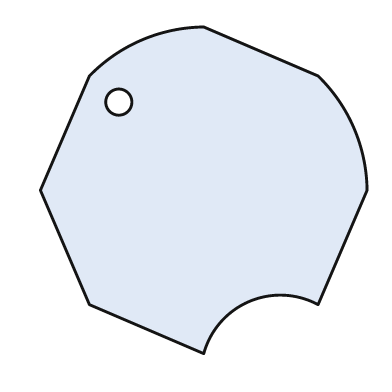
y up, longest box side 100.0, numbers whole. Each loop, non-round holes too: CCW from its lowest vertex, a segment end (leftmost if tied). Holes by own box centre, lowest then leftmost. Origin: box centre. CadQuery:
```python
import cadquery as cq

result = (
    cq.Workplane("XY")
    .moveTo(0.0, -50.0)
    .threePointArc((14.0, -34.0), (35.0, -35.0))
    .lineTo(50.0, 0.0)
    .threePointArc((46.0, 19.0), (35.0, 35.0))
    .lineTo(0.0, 50.0)
    .threePointArc((-19.0, 46.0), (-35.0, 35.0))
    .lineTo(-50.0, 0.0)
    .lineTo(-35.0, -35.0)
    .close()
    .moveTo(-26.0, 27.0)
    .circle(4.0)
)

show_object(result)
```